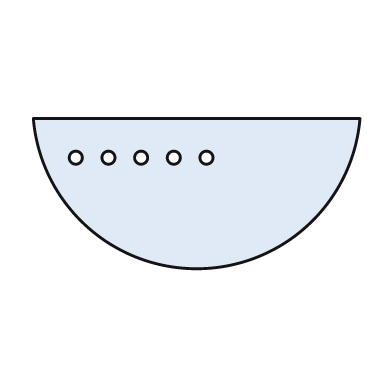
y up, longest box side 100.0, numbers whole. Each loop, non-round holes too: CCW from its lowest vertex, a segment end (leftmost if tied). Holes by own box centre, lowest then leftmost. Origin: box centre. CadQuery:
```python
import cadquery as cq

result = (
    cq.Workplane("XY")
    .moveTo(-50.0, 23.0)
    .threePointArc((0.0, -23.0), (50.0, 23.0))
    .close()
    .moveTo(-37.0, 11.0)
    .circle(2.0)
    .moveTo(-27.0, 11.0)
    .circle(2.0)
    .moveTo(-17.0, 11.0)
    .circle(2.0)
    .moveTo(-7.0, 11.0)
    .circle(2.0)
    .moveTo(3.0, 11.0)
    .circle(2.0)
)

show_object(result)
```